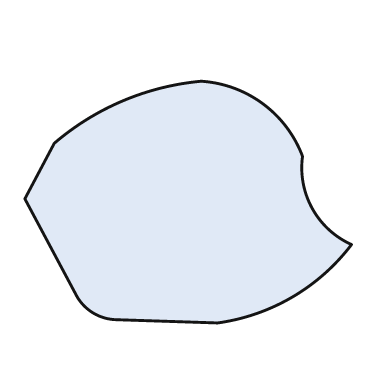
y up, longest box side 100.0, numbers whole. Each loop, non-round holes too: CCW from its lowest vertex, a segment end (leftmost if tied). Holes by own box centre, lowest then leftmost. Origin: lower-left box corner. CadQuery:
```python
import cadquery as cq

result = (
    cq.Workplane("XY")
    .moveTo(59.0, 0.0)
    .threePointArc((82.0, 8.0), (100.0, 24.0))
    .threePointArc((88.0, 35.0), (85.0, 51.0))
    .threePointArc((73.0, 67.0), (54.0, 74.0))
    .threePointArc((30.0, 68.0), (9.0, 55.0))
    .lineTo(0.0, 38.0)
    .lineTo(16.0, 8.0)
    .threePointArc((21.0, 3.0), (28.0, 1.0))
    .close()
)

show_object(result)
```